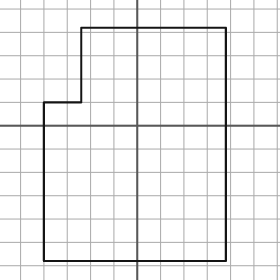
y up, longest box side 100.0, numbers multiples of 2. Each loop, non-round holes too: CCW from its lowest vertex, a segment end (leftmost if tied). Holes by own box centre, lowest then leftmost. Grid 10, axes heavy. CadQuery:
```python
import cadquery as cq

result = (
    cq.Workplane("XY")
    .moveTo(-40.0, -58.0)
    .lineTo(38.0, -58.0)
    .lineTo(38.0, 42.0)
    .lineTo(-24.0, 42.0)
    .lineTo(-24.0, 10.0)
    .lineTo(-40.0, 10.0)
    .close()
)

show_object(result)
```